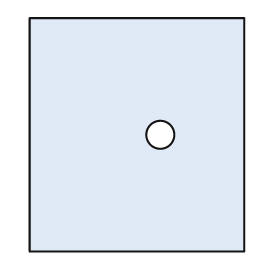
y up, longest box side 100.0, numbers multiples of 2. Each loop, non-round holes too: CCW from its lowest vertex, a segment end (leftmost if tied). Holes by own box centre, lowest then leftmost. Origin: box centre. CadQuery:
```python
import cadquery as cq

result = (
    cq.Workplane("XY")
    .moveTo(-46.0, -50.0)
    .lineTo(46.0, -50.0)
    .lineTo(46.0, 50.0)
    .lineTo(-46.0, 50.0)
    .close()
    .moveTo(10.0, 0.0)
    .circle(6.0)
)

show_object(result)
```